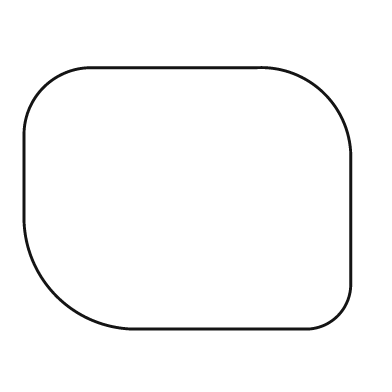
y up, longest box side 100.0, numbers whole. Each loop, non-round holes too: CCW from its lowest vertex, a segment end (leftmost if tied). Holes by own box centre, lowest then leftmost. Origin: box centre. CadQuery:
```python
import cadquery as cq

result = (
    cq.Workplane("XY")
    .moveTo(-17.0, -40.0)
    .lineTo(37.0, -40.0)
    .threePointArc((46.0, -36.0), (50.0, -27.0))
    .lineTo(50.0, 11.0)
    .threePointArc((42.0, 32.0), (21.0, 40.0))
    .lineTo(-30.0, 40.0)
    .threePointArc((-44.0, 34.0), (-50.0, 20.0))
    .lineTo(-50.0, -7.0)
    .threePointArc((-40.0, -30.0), (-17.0, -40.0))
    .close()
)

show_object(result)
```